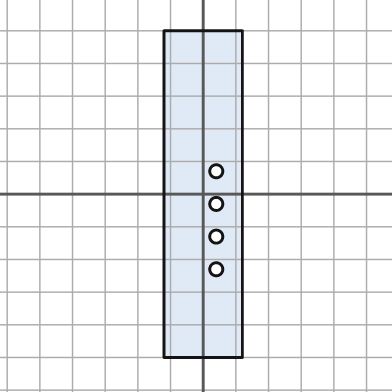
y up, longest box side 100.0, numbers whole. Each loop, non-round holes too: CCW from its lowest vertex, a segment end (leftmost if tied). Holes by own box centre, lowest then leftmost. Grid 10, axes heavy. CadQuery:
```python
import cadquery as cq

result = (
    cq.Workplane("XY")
    .moveTo(-12.0, -50.0)
    .lineTo(12.0, -50.0)
    .lineTo(12.0, 50.0)
    .lineTo(-12.0, 50.0)
    .close()
    .moveTo(4.0, -23.0)
    .circle(2.0)
    .moveTo(4.0, -13.0)
    .circle(2.0)
    .moveTo(4.0, -3.0)
    .circle(2.0)
    .moveTo(4.0, 7.0)
    .circle(2.0)
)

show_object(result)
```